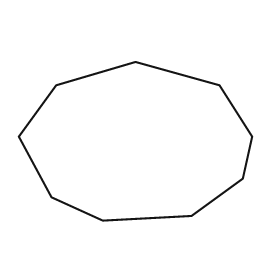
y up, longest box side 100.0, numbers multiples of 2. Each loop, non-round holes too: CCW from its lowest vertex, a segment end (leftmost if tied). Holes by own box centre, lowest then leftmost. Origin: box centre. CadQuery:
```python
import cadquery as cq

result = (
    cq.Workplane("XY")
    .moveTo(-14.0, -34.0)
    .lineTo(24.0, -32.0)
    .lineTo(46.0, -16.0)
    .lineTo(50.0, 2.0)
    .lineTo(36.0, 24.0)
    .lineTo(0.0, 34.0)
    .lineTo(-34.0, 24.0)
    .lineTo(-50.0, 2.0)
    .lineTo(-36.0, -24.0)
    .close()
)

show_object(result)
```